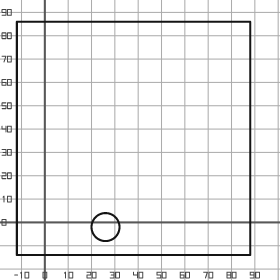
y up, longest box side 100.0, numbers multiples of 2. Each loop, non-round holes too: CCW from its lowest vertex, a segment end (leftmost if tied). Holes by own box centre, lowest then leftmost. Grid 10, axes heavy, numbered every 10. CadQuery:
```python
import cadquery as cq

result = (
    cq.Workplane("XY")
    .moveTo(-12.0, -14.0)
    .lineTo(88.0, -14.0)
    .lineTo(88.0, 86.0)
    .lineTo(-12.0, 86.0)
    .close()
    .moveTo(26.0, -2.0)
    .circle(6.0)
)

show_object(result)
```